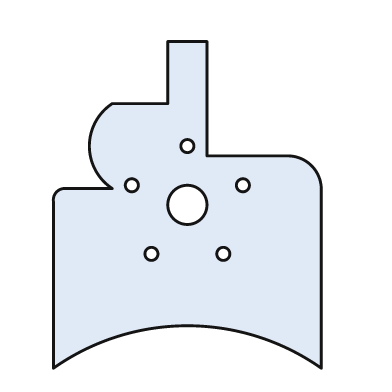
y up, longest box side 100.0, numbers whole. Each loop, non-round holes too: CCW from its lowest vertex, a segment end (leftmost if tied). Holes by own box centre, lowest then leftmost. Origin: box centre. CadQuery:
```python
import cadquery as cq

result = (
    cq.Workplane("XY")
    .moveTo(-41.0, -50.0)
    .threePointArc((0.0, -37.0), (41.0, -50.0))
    .lineTo(41.0, 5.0)
    .threePointArc((38.0, 12.0), (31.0, 15.0))
    .lineTo(6.0, 15.0)
    .lineTo(6.0, 50.0)
    .lineTo(-6.0, 50.0)
    .lineTo(-6.0, 31.0)
    .lineTo(-23.0, 31.0)
    .threePointArc((-30.0, 18.0), (-23.0, 5.0))
    .lineTo(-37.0, 5.0)
    .threePointArc((-40.0, 4.0), (-41.0, 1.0))
    .close()
    .moveTo(-11.0, -15.0)
    .circle(2.0)
    .moveTo(11.0, -15.0)
    .circle(2.0)
    .moveTo(0.0, 0.0)
    .circle(6.0)
    .moveTo(-17.0, 6.0)
    .circle(2.0)
    .moveTo(17.0, 6.0)
    .circle(2.0)
    .moveTo(0.0, 18.0)
    .circle(2.0)
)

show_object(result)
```